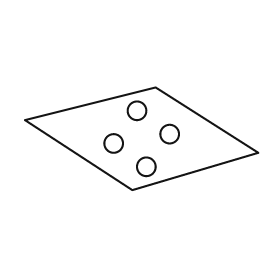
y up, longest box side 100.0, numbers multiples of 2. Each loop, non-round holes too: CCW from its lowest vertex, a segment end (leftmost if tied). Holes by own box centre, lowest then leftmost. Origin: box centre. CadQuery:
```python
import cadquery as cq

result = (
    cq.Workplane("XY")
    .moveTo(-4.0, -22.0)
    .lineTo(50.0, -6.0)
    .lineTo(6.0, 22.0)
    .lineTo(-50.0, 8.0)
    .close()
    .moveTo(2.0, -12.0)
    .circle(4.0)
    .moveTo(-12.0, -2.0)
    .circle(4.0)
    .moveTo(12.0, 2.0)
    .circle(4.0)
    .moveTo(-2.0, 12.0)
    .circle(4.0)
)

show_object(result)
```